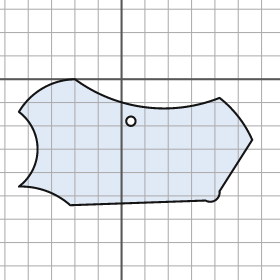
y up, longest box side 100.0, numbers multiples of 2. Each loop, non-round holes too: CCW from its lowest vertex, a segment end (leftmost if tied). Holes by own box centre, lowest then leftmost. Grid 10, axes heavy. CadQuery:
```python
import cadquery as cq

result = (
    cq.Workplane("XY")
    .moveTo(-22.0, -54.0)
    .lineTo(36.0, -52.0)
    .threePointArc((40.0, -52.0), (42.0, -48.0))
    .lineTo(56.0, -26.0)
    .threePointArc((50.0, -16.0), (42.0, -8.0))
    .threePointArc((10.0, -12.0), (-20.0, 0.0))
    .threePointArc((-34.0, -4.0), (-44.0, -14.0))
    .threePointArc((-36.0, -30.0), (-44.0, -46.0))
    .threePointArc((-32.0, -48.0), (-22.0, -54.0))
    .close()
    .moveTo(4.0, -18.0)
    .circle(2.0)
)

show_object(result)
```